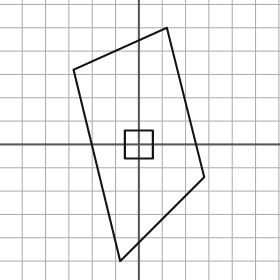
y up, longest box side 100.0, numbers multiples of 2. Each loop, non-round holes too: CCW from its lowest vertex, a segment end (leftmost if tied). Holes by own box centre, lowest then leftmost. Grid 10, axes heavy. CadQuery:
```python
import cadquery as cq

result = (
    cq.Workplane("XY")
    .moveTo(-8.0, -50.0)
    .lineTo(28.0, -14.0)
    .lineTo(12.0, 50.0)
    .lineTo(-28.0, 32.0)
    .close()
    .moveTo(-6.0, -6.0)
    .lineTo(6.0, -6.0)
    .lineTo(6.0, 6.0)
    .lineTo(-6.0, 6.0)
    .close()
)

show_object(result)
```